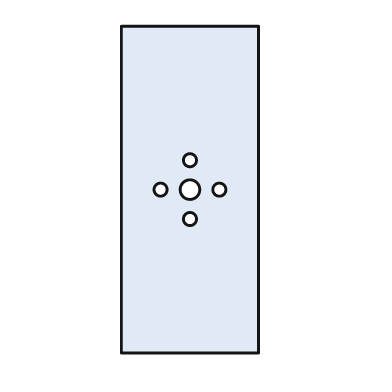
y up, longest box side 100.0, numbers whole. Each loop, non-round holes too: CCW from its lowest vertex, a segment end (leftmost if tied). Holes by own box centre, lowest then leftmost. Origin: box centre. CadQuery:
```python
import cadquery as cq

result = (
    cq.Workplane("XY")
    .moveTo(-21.0, -50.0)
    .lineTo(21.0, -50.0)
    .lineTo(21.0, 50.0)
    .lineTo(-21.0, 50.0)
    .close()
    .moveTo(0.0, -9.0)
    .circle(2.0)
    .moveTo(-9.0, 0.0)
    .circle(2.0)
    .moveTo(0.0, 0.0)
    .circle(3.0)
    .moveTo(9.0, 0.0)
    .circle(2.0)
    .moveTo(0.0, 9.0)
    .circle(2.0)
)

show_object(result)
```